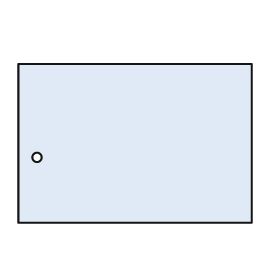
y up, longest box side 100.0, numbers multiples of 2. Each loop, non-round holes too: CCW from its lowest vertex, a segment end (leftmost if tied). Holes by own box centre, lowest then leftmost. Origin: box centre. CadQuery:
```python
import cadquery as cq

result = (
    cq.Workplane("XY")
    .moveTo(-50.0, -34.0)
    .lineTo(50.0, -34.0)
    .lineTo(50.0, 34.0)
    .lineTo(-50.0, 34.0)
    .close()
    .moveTo(-42.0, -6.0)
    .circle(2.0)
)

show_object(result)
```